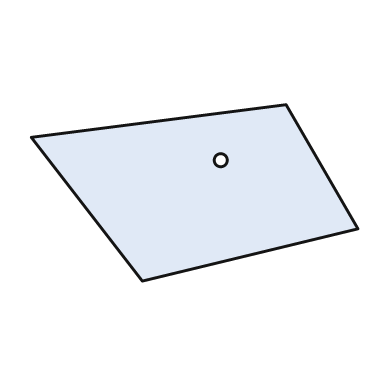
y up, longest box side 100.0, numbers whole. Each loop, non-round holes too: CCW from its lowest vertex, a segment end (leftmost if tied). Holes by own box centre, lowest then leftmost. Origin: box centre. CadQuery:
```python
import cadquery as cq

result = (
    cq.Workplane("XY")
    .moveTo(-16.0, -27.0)
    .lineTo(50.0, -11.0)
    .lineTo(28.0, 27.0)
    .lineTo(-50.0, 17.0)
    .close()
    .moveTo(8.0, 10.0)
    .circle(2.0)
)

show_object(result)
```